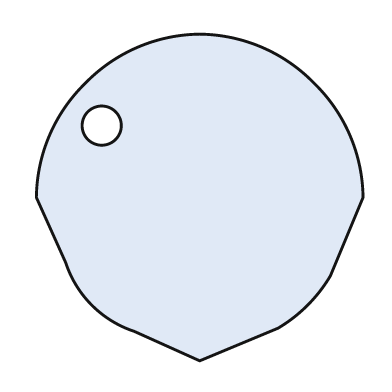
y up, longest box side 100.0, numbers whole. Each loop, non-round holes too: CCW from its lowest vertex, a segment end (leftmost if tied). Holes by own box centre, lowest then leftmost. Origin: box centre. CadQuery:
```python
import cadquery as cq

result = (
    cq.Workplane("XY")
    .moveTo(0.0, -50.0)
    .lineTo(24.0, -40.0)
    .threePointArc((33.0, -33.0), (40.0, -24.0))
    .lineTo(50.0, 0.0)
    .threePointArc((46.0, 19.0), (35.0, 35.0))
    .threePointArc((19.0, 46.0), (0.0, 50.0))
    .threePointArc((-19.0, 46.0), (-35.0, 35.0))
    .threePointArc((-46.0, 19.0), (-50.0, 0.0))
    .lineTo(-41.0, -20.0)
    .threePointArc((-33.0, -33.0), (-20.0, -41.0))
    .close()
    .moveTo(-30.0, 22.0)
    .circle(6.0)
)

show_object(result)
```